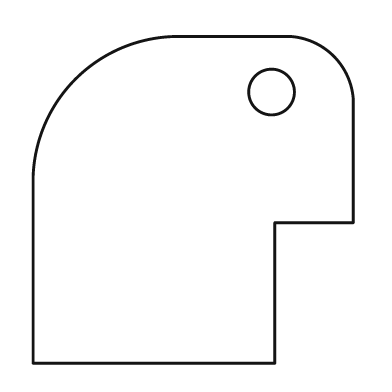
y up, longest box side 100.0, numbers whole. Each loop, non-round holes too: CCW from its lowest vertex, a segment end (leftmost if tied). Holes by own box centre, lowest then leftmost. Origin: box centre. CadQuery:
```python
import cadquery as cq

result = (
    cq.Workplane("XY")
    .moveTo(-49.0, -50.0)
    .lineTo(25.0, -50.0)
    .lineTo(25.0, -7.0)
    .lineTo(49.0, -7.0)
    .lineTo(49.0, 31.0)
    .threePointArc((43.0, 44.0), (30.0, 50.0))
    .lineTo(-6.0, 50.0)
    .threePointArc((-36.0, 37.0), (-49.0, 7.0))
    .close()
    .moveTo(24.0, 33.0)
    .circle(7.0)
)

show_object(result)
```